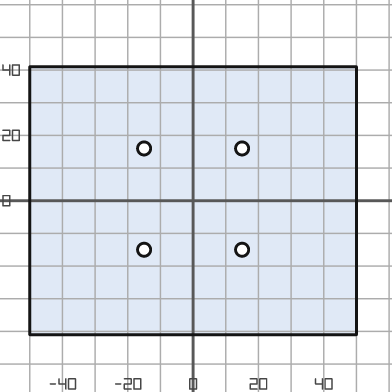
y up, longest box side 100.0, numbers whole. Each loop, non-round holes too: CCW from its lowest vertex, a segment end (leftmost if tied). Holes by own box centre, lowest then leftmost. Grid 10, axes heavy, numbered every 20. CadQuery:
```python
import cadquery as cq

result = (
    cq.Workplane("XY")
    .moveTo(-50.0, -41.0)
    .lineTo(50.0, -41.0)
    .lineTo(50.0, 41.0)
    .lineTo(-50.0, 41.0)
    .close()
    .moveTo(-15.0, -15.0)
    .circle(2.0)
    .moveTo(15.0, -15.0)
    .circle(2.0)
    .moveTo(-15.0, 16.0)
    .circle(2.0)
    .moveTo(15.0, 16.0)
    .circle(2.0)
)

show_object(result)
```